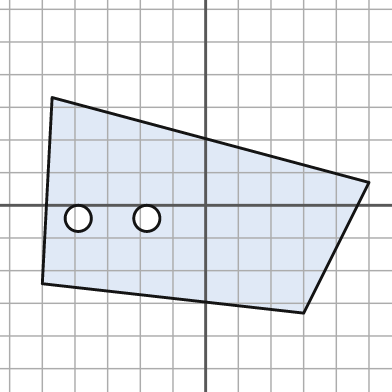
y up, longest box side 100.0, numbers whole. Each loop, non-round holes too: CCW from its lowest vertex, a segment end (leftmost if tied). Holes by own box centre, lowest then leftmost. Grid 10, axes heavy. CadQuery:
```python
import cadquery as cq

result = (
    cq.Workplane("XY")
    .moveTo(30.0, -33.0)
    .lineTo(50.0, 7.0)
    .lineTo(-47.0, 33.0)
    .lineTo(-50.0, -24.0)
    .close()
    .moveTo(-39.0, -4.0)
    .circle(4.0)
    .moveTo(-18.0, -4.0)
    .circle(4.0)
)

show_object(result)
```